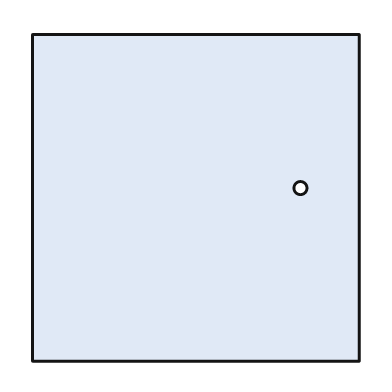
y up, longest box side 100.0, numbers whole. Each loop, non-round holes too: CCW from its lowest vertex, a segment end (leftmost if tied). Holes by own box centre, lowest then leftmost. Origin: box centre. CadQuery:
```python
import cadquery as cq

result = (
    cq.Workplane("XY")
    .moveTo(-50.0, -50.0)
    .lineTo(50.0, -50.0)
    .lineTo(50.0, 50.0)
    .lineTo(-50.0, 50.0)
    .close()
    .moveTo(32.0, 3.0)
    .circle(2.0)
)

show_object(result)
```